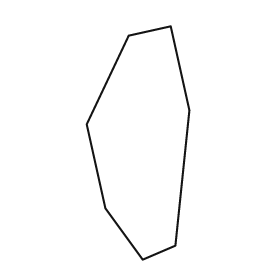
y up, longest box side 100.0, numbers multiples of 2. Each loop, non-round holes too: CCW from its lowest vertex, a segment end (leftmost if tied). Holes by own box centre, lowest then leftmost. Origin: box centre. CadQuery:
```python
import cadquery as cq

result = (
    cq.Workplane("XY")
    .moveTo(2.0, -50.0)
    .lineTo(16.0, -44.0)
    .lineTo(22.0, 14.0)
    .lineTo(14.0, 50.0)
    .lineTo(-4.0, 46.0)
    .lineTo(-22.0, 8.0)
    .lineTo(-14.0, -28.0)
    .close()
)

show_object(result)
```